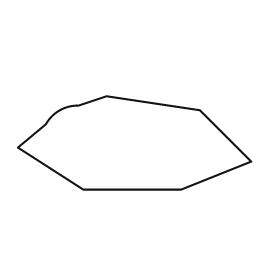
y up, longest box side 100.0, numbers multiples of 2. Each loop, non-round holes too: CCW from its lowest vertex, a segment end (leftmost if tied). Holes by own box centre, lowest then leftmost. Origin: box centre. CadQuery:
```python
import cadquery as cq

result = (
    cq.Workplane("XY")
    .moveTo(-22.0, -20.0)
    .lineTo(20.0, -20.0)
    .lineTo(50.0, -8.0)
    .lineTo(28.0, 14.0)
    .lineTo(-12.0, 20.0)
    .lineTo(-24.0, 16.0)
    .threePointArc((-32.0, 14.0), (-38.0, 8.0))
    .lineTo(-50.0, -2.0)
    .close()
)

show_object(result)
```